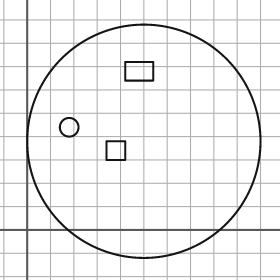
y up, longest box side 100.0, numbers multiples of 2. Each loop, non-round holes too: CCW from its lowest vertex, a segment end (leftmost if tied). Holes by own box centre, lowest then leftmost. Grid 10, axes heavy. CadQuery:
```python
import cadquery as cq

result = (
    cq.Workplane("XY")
    .moveTo(50.0, 38.0)
    .circle(50.0)
    .moveTo(34.0, 30.0)
    .lineTo(42.0, 30.0)
    .lineTo(42.0, 38.0)
    .lineTo(34.0, 38.0)
    .close()
    .moveTo(18.0, 44.0)
    .circle(4.0)
    .moveTo(42.0, 64.0)
    .lineTo(54.0, 64.0)
    .lineTo(54.0, 72.0)
    .lineTo(42.0, 72.0)
    .close()
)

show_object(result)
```